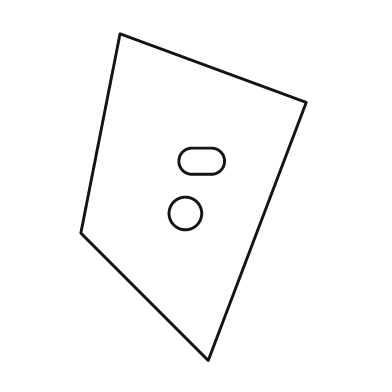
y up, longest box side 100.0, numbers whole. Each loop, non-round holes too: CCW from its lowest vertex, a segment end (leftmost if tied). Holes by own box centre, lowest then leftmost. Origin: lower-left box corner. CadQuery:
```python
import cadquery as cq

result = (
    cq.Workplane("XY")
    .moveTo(39.0, 0.0)
    .lineTo(69.0, 79.0)
    .lineTo(12.0, 100.0)
    .lineTo(0.0, 39.0)
    .close()
    .moveTo(32.0, 45.0)
    .circle(5.0)
    .moveTo(34.0, 57.0)
    .lineTo(40.0, 57.0)
    .threePointArc((44.0, 61.0), (40.0, 65.0))
    .lineTo(34.0, 65.0)
    .threePointArc((30.0, 61.0), (34.0, 57.0))
    .close()
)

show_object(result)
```